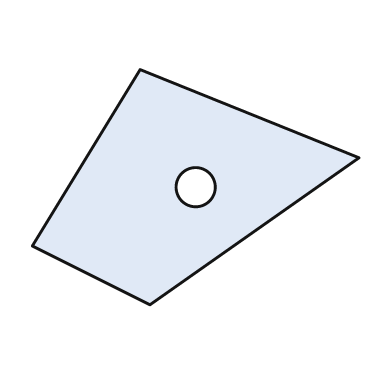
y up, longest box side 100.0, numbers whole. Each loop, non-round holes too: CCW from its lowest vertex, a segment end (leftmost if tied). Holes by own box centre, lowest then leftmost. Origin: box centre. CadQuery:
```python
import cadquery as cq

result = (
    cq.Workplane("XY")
    .moveTo(-14.0, -36.0)
    .lineTo(50.0, 9.0)
    .lineTo(-17.0, 36.0)
    .lineTo(-50.0, -18.0)
    .close()
    .moveTo(0.0, 0.0)
    .circle(6.0)
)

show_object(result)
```